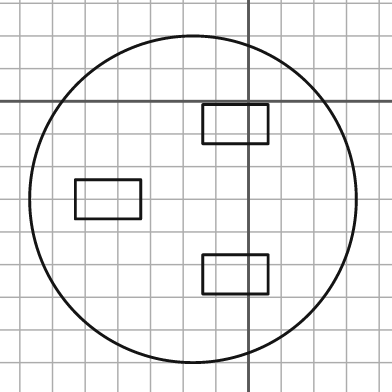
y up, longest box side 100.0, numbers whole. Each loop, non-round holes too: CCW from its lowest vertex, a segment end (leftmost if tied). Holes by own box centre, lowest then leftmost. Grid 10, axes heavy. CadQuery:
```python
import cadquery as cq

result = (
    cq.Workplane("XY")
    .moveTo(-17.0, -30.0)
    .circle(50.0)
    .moveTo(-14.0, -59.0)
    .lineTo(6.0, -59.0)
    .lineTo(6.0, -47.0)
    .lineTo(-14.0, -47.0)
    .close()
    .moveTo(-53.0, -36.0)
    .lineTo(-33.0, -36.0)
    .lineTo(-33.0, -24.0)
    .lineTo(-53.0, -24.0)
    .close()
    .moveTo(-14.0, -13.0)
    .lineTo(6.0, -13.0)
    .lineTo(6.0, -1.0)
    .lineTo(-14.0, -1.0)
    .close()
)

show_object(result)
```